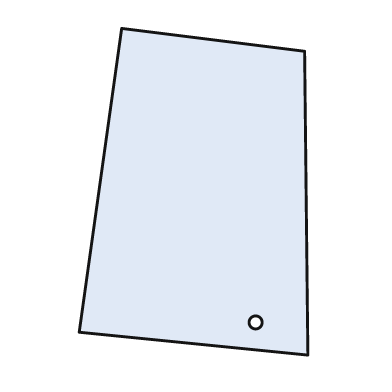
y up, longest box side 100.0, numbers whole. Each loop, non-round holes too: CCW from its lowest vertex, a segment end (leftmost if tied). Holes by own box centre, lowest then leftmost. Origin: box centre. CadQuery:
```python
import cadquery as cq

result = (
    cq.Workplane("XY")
    .moveTo(35.0, -50.0)
    .lineTo(34.0, 43.0)
    .lineTo(-22.0, 50.0)
    .lineTo(-35.0, -43.0)
    .close()
    .moveTo(19.0, -40.0)
    .circle(2.0)
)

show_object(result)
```